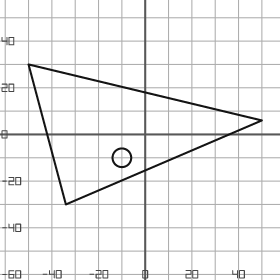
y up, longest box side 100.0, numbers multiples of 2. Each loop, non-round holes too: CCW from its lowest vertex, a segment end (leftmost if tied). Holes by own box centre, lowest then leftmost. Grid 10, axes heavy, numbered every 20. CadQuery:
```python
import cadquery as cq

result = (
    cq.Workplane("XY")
    .moveTo(-34.0, -30.0)
    .lineTo(50.0, 6.0)
    .lineTo(-50.0, 30.0)
    .close()
    .moveTo(-10.0, -10.0)
    .circle(4.0)
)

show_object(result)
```